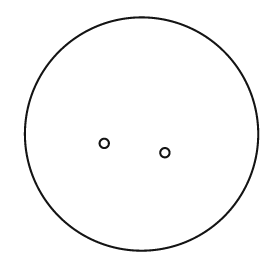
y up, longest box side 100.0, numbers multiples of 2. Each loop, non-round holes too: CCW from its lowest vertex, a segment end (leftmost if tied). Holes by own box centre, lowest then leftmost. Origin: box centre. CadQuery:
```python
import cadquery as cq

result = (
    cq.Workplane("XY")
    .moveTo(0.0, 0.0)
    .circle(50.0)
    .moveTo(10.0, -8.0)
    .circle(2.0)
    .moveTo(-16.0, -4.0)
    .circle(2.0)
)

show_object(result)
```